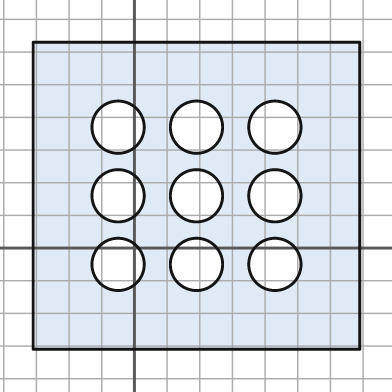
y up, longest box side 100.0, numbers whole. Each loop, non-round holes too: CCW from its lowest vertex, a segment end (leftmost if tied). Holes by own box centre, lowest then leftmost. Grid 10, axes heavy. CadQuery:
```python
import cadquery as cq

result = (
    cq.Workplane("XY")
    .moveTo(-31.0, -31.0)
    .lineTo(69.0, -31.0)
    .lineTo(69.0, 63.0)
    .lineTo(-31.0, 63.0)
    .close()
    .moveTo(-5.0, -5.0)
    .circle(8.0)
    .moveTo(19.0, -5.0)
    .circle(8.0)
    .moveTo(43.0, -5.0)
    .circle(8.0)
    .moveTo(-5.0, 16.0)
    .circle(8.0)
    .moveTo(19.0, 16.0)
    .circle(8.0)
    .moveTo(43.0, 16.0)
    .circle(8.0)
    .moveTo(-5.0, 37.0)
    .circle(8.0)
    .moveTo(19.0, 37.0)
    .circle(8.0)
    .moveTo(43.0, 37.0)
    .circle(8.0)
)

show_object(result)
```